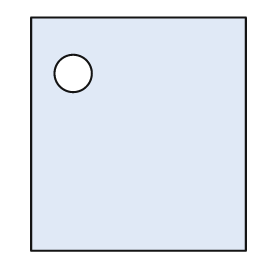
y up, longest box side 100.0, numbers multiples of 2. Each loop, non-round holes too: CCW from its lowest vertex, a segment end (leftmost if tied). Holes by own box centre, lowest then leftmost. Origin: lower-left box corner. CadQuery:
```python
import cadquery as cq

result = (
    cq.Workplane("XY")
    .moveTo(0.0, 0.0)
    .lineTo(92.0, 0.0)
    .lineTo(92.0, 100.0)
    .lineTo(0.0, 100.0)
    .close()
    .moveTo(18.0, 76.0)
    .circle(8.0)
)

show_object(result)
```